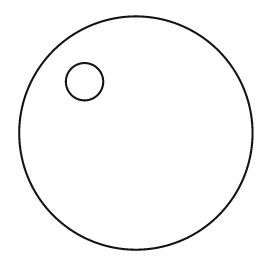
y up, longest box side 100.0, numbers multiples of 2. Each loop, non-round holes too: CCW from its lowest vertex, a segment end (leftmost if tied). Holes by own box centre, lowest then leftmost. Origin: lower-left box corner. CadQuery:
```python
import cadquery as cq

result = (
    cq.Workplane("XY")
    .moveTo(50.0, 50.0)
    .circle(50.0)
    .moveTo(28.0, 72.0)
    .circle(8.0)
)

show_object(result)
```